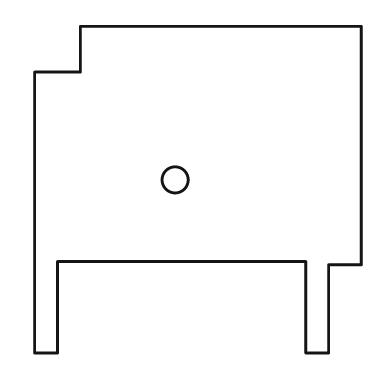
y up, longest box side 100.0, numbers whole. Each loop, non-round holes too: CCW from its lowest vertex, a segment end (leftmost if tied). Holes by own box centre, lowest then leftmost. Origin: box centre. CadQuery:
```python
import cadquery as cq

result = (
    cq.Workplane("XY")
    .moveTo(-50.0, -50.0)
    .lineTo(-43.0, -50.0)
    .lineTo(-43.0, -22.0)
    .lineTo(33.0, -22.0)
    .lineTo(33.0, -50.0)
    .lineTo(40.0, -50.0)
    .lineTo(40.0, -23.0)
    .lineTo(50.0, -23.0)
    .lineTo(50.0, 50.0)
    .lineTo(-36.0, 50.0)
    .lineTo(-36.0, 36.0)
    .lineTo(-50.0, 36.0)
    .close()
    .moveTo(-7.0, 3.0)
    .circle(4.0)
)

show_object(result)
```